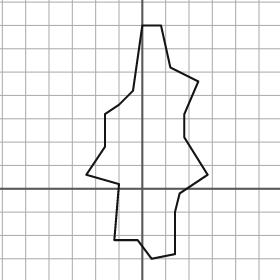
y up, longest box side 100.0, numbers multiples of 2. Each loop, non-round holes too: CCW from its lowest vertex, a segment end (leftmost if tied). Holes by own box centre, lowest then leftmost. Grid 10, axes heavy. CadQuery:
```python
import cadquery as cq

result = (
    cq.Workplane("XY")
    .moveTo(4.0, -30.0)
    .lineTo(14.0, -28.0)
    .lineTo(14.0, -10.0)
    .lineTo(16.0, -2.0)
    .lineTo(28.0, 6.0)
    .lineTo(18.0, 22.0)
    .lineTo(18.0, 32.0)
    .lineTo(24.0, 46.0)
    .lineTo(12.0, 52.0)
    .lineTo(8.0, 70.0)
    .lineTo(0.0, 70.0)
    .lineTo(-4.0, 42.0)
    .lineTo(-10.0, 36.0)
    .lineTo(-16.0, 32.0)
    .lineTo(-16.0, 18.0)
    .lineTo(-24.0, 6.0)
    .lineTo(-10.0, 2.0)
    .lineTo(-12.0, -22.0)
    .lineTo(-2.0, -22.0)
    .close()
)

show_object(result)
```